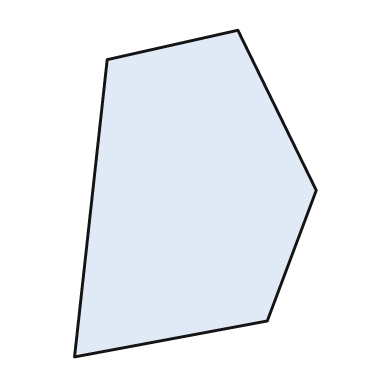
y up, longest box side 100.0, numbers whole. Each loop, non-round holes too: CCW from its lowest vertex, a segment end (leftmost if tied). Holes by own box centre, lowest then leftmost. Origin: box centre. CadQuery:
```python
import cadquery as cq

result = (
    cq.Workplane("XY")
    .moveTo(-37.0, -50.0)
    .lineTo(22.0, -39.0)
    .lineTo(37.0, 1.0)
    .lineTo(13.0, 50.0)
    .lineTo(-27.0, 41.0)
    .close()
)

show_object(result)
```